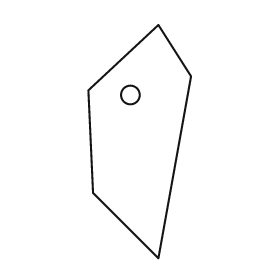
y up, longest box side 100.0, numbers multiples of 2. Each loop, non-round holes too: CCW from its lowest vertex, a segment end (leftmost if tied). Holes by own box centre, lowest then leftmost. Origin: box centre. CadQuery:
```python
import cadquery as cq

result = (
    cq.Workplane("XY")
    .moveTo(8.0, -50.0)
    .lineTo(22.0, 28.0)
    .lineTo(8.0, 50.0)
    .lineTo(-22.0, 22.0)
    .lineTo(-20.0, -22.0)
    .close()
    .moveTo(-4.0, 20.0)
    .circle(4.0)
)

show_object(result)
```